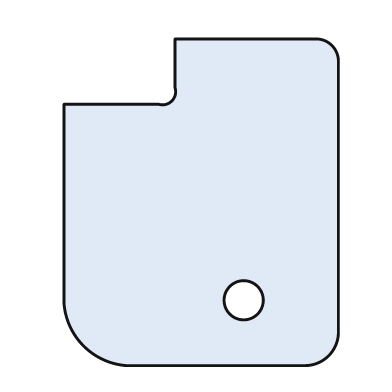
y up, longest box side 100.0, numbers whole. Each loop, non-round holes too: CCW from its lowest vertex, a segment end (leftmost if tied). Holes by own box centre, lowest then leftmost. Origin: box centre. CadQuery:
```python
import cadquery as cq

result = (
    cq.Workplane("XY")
    .moveTo(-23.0, -50.0)
    .lineTo(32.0, -50.0)
    .threePointArc((39.0, -47.0), (42.0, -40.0))
    .lineTo(42.0, 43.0)
    .threePointArc((40.0, 48.0), (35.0, 50.0))
    .lineTo(-8.0, 50.0)
    .lineTo(-8.0, 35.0)
    .threePointArc((-9.0, 31.0), (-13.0, 30.0))
    .lineTo(-42.0, 30.0)
    .lineTo(-42.0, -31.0)
    .threePointArc((-36.0, -44.0), (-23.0, -50.0))
    .close()
    .moveTo(13.0, -30.0)
    .circle(6.0)
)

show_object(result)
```